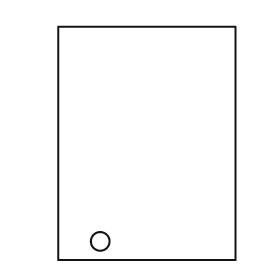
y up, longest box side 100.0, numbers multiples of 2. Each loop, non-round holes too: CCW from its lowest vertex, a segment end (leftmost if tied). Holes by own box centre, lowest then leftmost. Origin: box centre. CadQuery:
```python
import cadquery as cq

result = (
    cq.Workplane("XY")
    .moveTo(-38.0, -50.0)
    .lineTo(38.0, -50.0)
    .lineTo(38.0, 50.0)
    .lineTo(-38.0, 50.0)
    .close()
    .moveTo(-20.0, -42.0)
    .circle(4.0)
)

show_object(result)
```